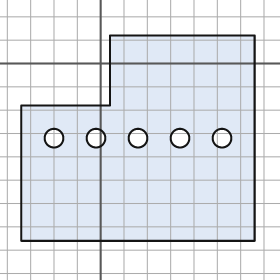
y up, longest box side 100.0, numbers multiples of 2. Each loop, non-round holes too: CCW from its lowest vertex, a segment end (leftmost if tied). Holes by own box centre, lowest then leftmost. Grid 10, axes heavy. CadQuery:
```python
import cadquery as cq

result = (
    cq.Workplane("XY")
    .moveTo(-34.0, -76.0)
    .lineTo(66.0, -76.0)
    .lineTo(66.0, 12.0)
    .lineTo(4.0, 12.0)
    .lineTo(4.0, -18.0)
    .lineTo(-34.0, -18.0)
    .close()
    .moveTo(-20.0, -32.0)
    .circle(4.0)
    .moveTo(-2.0, -32.0)
    .circle(4.0)
    .moveTo(16.0, -32.0)
    .circle(4.0)
    .moveTo(34.0, -32.0)
    .circle(4.0)
    .moveTo(52.0, -32.0)
    .circle(4.0)
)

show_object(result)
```